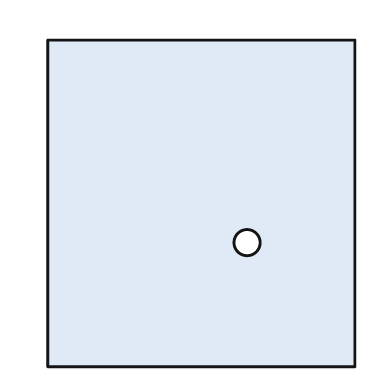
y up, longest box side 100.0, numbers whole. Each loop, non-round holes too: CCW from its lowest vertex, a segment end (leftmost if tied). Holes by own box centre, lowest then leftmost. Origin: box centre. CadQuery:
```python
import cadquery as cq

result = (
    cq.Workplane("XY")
    .moveTo(-47.0, -50.0)
    .lineTo(47.0, -50.0)
    .lineTo(47.0, 50.0)
    .lineTo(-47.0, 50.0)
    .close()
    .moveTo(14.0, -12.0)
    .circle(4.0)
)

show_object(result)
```